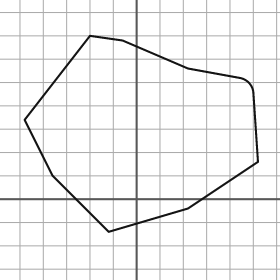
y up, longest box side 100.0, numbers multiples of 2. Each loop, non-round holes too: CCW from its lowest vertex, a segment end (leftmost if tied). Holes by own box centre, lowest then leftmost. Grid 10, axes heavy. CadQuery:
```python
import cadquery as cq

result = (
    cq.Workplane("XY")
    .moveTo(-12.0, -14.0)
    .lineTo(22.0, -4.0)
    .lineTo(52.0, 16.0)
    .lineTo(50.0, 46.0)
    .threePointArc((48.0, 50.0), (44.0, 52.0))
    .lineTo(22.0, 56.0)
    .lineTo(-6.0, 68.0)
    .lineTo(-20.0, 70.0)
    .lineTo(-48.0, 34.0)
    .lineTo(-36.0, 10.0)
    .close()
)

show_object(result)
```